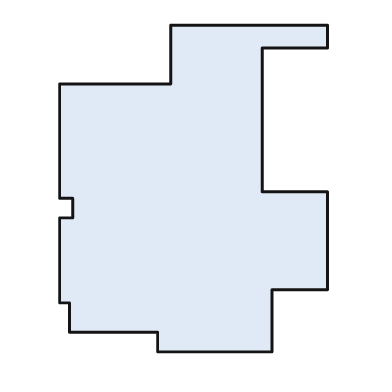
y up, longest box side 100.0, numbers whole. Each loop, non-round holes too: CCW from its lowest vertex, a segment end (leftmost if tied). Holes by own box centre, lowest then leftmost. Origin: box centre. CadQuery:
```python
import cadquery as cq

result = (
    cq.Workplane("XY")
    .moveTo(-11.0, -50.0)
    .lineTo(24.0, -50.0)
    .lineTo(24.0, -31.0)
    .lineTo(41.0, -31.0)
    .lineTo(41.0, -1.0)
    .lineTo(21.0, -1.0)
    .lineTo(21.0, 43.0)
    .lineTo(41.0, 43.0)
    .lineTo(41.0, 50.0)
    .lineTo(-7.0, 50.0)
    .lineTo(-7.0, 32.0)
    .lineTo(-41.0, 32.0)
    .lineTo(-41.0, -3.0)
    .lineTo(-37.0, -3.0)
    .lineTo(-37.0, -9.0)
    .lineTo(-41.0, -9.0)
    .lineTo(-41.0, -35.0)
    .lineTo(-38.0, -35.0)
    .lineTo(-38.0, -44.0)
    .lineTo(-11.0, -44.0)
    .close()
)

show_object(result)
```